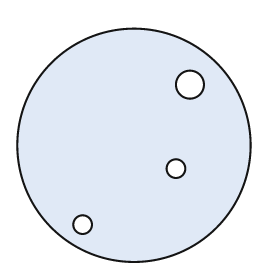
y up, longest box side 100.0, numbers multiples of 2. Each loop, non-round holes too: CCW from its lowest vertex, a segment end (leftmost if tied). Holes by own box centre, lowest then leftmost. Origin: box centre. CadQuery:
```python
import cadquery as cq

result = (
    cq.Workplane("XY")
    .moveTo(0.0, 0.0)
    .circle(50.0)
    .moveTo(-22.0, -34.0)
    .circle(4.0)
    .moveTo(18.0, -10.0)
    .circle(4.0)
    .moveTo(24.0, 26.0)
    .circle(6.0)
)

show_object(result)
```